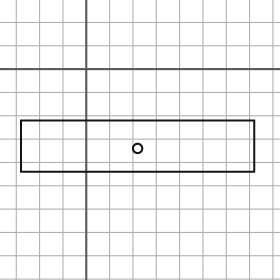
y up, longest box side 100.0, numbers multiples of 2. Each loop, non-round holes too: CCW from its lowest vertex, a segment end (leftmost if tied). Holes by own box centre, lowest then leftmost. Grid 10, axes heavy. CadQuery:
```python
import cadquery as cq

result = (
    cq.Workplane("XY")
    .moveTo(-28.0, -44.0)
    .lineTo(72.0, -44.0)
    .lineTo(72.0, -22.0)
    .lineTo(-28.0, -22.0)
    .close()
    .moveTo(22.0, -34.0)
    .circle(2.0)
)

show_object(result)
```